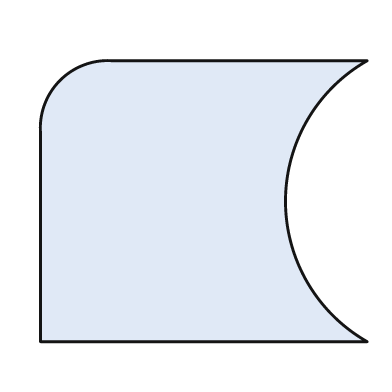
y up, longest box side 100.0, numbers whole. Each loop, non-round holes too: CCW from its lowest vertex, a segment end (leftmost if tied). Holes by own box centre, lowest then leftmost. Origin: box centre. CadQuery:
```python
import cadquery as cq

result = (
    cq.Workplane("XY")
    .moveTo(-50.0, -43.0)
    .lineTo(50.0, -43.0)
    .threePointArc((25.0, 0.0), (50.0, 43.0))
    .lineTo(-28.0, 43.0)
    .threePointArc((-44.0, 37.0), (-50.0, 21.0))
    .close()
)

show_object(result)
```